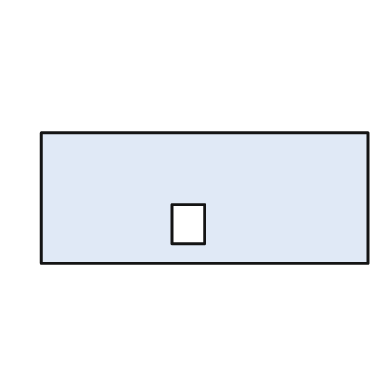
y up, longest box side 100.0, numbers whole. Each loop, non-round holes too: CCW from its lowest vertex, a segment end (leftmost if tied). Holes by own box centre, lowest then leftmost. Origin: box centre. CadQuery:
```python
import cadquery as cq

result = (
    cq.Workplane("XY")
    .moveTo(-50.0, -20.0)
    .lineTo(50.0, -20.0)
    .lineTo(50.0, 20.0)
    .lineTo(-50.0, 20.0)
    .close()
    .moveTo(-10.0, -14.0)
    .lineTo(0.0, -14.0)
    .lineTo(0.0, -2.0)
    .lineTo(-10.0, -2.0)
    .close()
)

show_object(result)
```